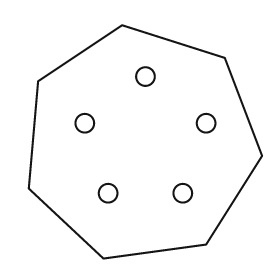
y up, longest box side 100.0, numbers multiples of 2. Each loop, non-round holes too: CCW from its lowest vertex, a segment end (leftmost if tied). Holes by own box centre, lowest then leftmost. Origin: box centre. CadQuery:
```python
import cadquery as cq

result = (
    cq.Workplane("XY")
    .moveTo(-18.0, -50.0)
    .lineTo(26.0, -44.0)
    .lineTo(50.0, -6.0)
    .lineTo(34.0, 36.0)
    .lineTo(-10.0, 50.0)
    .lineTo(-46.0, 26.0)
    .lineTo(-50.0, -20.0)
    .close()
    .moveTo(-16.0, -22.0)
    .circle(4.0)
    .moveTo(16.0, -22.0)
    .circle(4.0)
    .moveTo(-26.0, 8.0)
    .circle(4.0)
    .moveTo(26.0, 8.0)
    .circle(4.0)
    .moveTo(0.0, 28.0)
    .circle(4.0)
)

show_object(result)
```